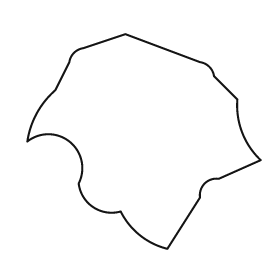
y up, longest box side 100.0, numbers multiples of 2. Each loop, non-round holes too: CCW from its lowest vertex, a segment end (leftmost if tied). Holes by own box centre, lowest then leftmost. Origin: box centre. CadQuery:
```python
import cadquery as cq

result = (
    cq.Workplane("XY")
    .moveTo(10.0, -46.0)
    .lineTo(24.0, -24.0)
    .threePointArc((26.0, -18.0), (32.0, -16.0))
    .lineTo(50.0, -8.0)
    .threePointArc((42.0, 4.0), (40.0, 18.0))
    .lineTo(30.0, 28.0)
    .threePointArc((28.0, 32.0), (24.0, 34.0))
    .lineTo(-8.0, 46.0)
    .lineTo(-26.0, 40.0)
    .threePointArc((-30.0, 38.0), (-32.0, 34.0))
    .lineTo(-38.0, 22.0)
    .threePointArc((-46.0, 12.0), (-50.0, 0.0))
    .threePointArc((-32.0, 0.0), (-28.0, -18.0))
    .threePointArc((-22.0, -28.0), (-10.0, -30.0))
    .threePointArc((-2.0, -40.0), (10.0, -46.0))
    .close()
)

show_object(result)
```